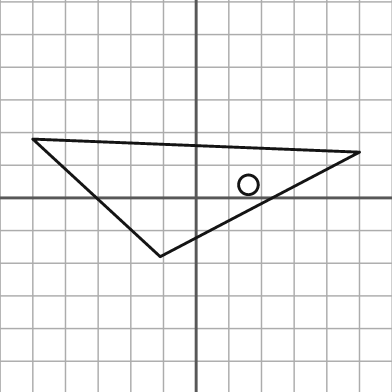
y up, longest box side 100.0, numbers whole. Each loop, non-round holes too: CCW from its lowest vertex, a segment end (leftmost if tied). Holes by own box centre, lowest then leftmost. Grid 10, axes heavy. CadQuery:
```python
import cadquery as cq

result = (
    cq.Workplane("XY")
    .moveTo(-11.0, -18.0)
    .lineTo(50.0, 14.0)
    .lineTo(-50.0, 18.0)
    .close()
    .moveTo(16.0, 4.0)
    .circle(3.0)
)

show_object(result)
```